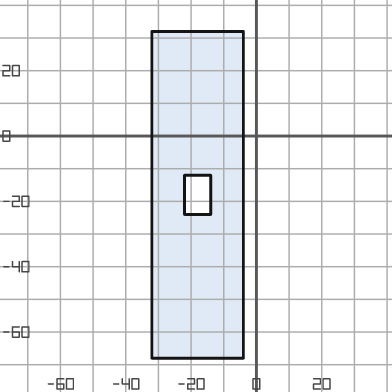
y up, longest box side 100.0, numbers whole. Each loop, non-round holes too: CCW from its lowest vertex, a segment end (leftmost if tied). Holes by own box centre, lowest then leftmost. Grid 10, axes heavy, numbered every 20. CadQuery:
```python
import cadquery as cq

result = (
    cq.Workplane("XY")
    .moveTo(-32.0, -68.0)
    .lineTo(-4.0, -68.0)
    .lineTo(-4.0, 32.0)
    .lineTo(-32.0, 32.0)
    .close()
    .moveTo(-22.0, -24.0)
    .lineTo(-14.0, -24.0)
    .lineTo(-14.0, -12.0)
    .lineTo(-22.0, -12.0)
    .close()
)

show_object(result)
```